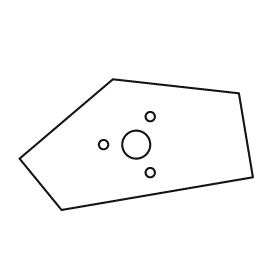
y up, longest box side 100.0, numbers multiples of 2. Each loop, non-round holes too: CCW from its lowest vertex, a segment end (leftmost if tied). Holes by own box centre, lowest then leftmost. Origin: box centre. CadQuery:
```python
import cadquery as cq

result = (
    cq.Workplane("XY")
    .moveTo(-32.0, -28.0)
    .lineTo(50.0, -14.0)
    .lineTo(44.0, 22.0)
    .lineTo(-10.0, 28.0)
    .lineTo(-50.0, -6.0)
    .close()
    .moveTo(6.0, -12.0)
    .circle(2.0)
    .moveTo(-14.0, 0.0)
    .circle(2.0)
    .moveTo(0.0, 0.0)
    .circle(6.0)
    .moveTo(6.0, 12.0)
    .circle(2.0)
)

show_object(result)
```